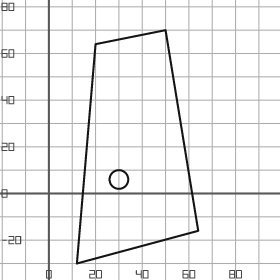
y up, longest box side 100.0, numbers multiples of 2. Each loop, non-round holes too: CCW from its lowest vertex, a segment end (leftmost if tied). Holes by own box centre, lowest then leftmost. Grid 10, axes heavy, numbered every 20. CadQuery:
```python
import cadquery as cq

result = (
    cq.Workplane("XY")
    .moveTo(12.0, -30.0)
    .lineTo(64.0, -16.0)
    .lineTo(50.0, 70.0)
    .lineTo(20.0, 64.0)
    .close()
    .moveTo(30.0, 6.0)
    .circle(4.0)
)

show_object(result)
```